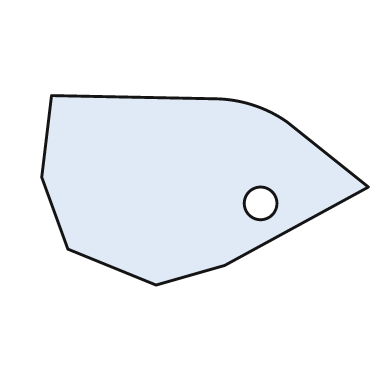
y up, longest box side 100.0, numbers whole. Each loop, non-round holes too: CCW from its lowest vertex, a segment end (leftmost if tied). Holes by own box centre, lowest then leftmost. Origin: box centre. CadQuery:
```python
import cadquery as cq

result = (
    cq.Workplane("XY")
    .moveTo(-15.0, -29.0)
    .lineTo(6.0, -23.0)
    .lineTo(50.0, 1.0)
    .lineTo(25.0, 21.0)
    .threePointArc((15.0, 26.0), (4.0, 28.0))
    .lineTo(-47.0, 29.0)
    .lineTo(-50.0, 4.0)
    .lineTo(-42.0, -18.0)
    .close()
    .moveTo(17.0, -4.0)
    .circle(5.0)
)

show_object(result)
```